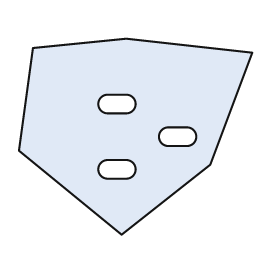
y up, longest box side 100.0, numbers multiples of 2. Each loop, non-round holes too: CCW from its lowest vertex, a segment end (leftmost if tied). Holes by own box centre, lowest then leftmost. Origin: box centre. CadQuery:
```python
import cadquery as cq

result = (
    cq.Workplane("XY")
    .moveTo(-6.0, -42.0)
    .lineTo(32.0, -12.0)
    .lineTo(50.0, 36.0)
    .lineTo(-4.0, 42.0)
    .lineTo(-44.0, 38.0)
    .lineTo(-50.0, -6.0)
    .close()
    .moveTo(-12.0, -18.0)
    .lineTo(-4.0, -18.0)
    .threePointArc((0.0, -14.0), (-4.0, -10.0))
    .lineTo(-12.0, -10.0)
    .threePointArc((-16.0, -14.0), (-12.0, -18.0))
    .close()
    .moveTo(14.0, -4.0)
    .lineTo(22.0, -4.0)
    .threePointArc((26.0, 0.0), (22.0, 4.0))
    .lineTo(14.0, 4.0)
    .threePointArc((10.0, 0.0), (14.0, -4.0))
    .close()
    .moveTo(-12.0, 10.0)
    .lineTo(-4.0, 10.0)
    .threePointArc((0.0, 14.0), (-4.0, 18.0))
    .lineTo(-12.0, 18.0)
    .threePointArc((-16.0, 14.0), (-12.0, 10.0))
    .close()
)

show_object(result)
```